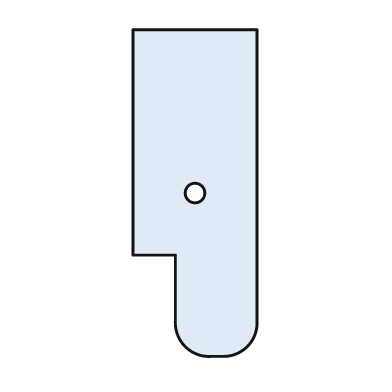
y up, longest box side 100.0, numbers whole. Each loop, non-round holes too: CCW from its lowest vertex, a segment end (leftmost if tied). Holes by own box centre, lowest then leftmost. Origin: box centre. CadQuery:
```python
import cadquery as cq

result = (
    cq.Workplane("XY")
    .moveTo(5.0, -50.0)
    .lineTo(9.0, -50.0)
    .threePointArc((16.0, -47.0), (19.0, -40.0))
    .lineTo(19.0, 50.0)
    .lineTo(-19.0, 50.0)
    .lineTo(-19.0, -19.0)
    .lineTo(-6.0, -19.0)
    .lineTo(-6.0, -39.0)
    .threePointArc((-3.0, -47.0), (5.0, -50.0))
    .close()
    .moveTo(0.0, 0.0)
    .circle(3.0)
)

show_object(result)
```